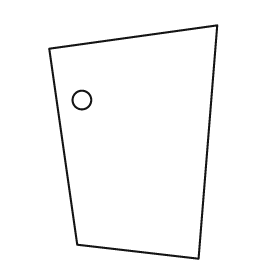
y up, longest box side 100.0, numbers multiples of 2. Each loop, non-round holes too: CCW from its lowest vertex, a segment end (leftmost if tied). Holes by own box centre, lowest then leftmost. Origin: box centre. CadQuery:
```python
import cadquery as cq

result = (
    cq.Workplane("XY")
    .moveTo(28.0, -50.0)
    .lineTo(36.0, 50.0)
    .lineTo(-36.0, 40.0)
    .lineTo(-24.0, -44.0)
    .close()
    .moveTo(-22.0, 18.0)
    .circle(4.0)
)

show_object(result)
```